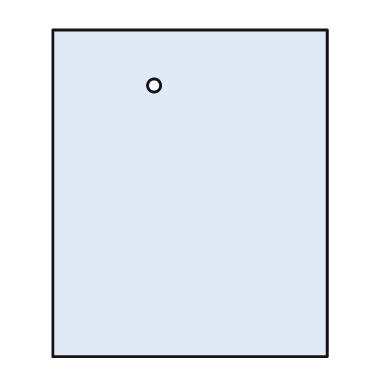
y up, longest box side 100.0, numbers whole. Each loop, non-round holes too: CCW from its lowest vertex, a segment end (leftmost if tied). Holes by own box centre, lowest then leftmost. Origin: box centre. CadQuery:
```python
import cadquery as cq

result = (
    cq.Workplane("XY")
    .moveTo(-42.0, -50.0)
    .lineTo(42.0, -50.0)
    .lineTo(42.0, 50.0)
    .lineTo(-42.0, 50.0)
    .close()
    .moveTo(-11.0, 33.0)
    .circle(2.0)
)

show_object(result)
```